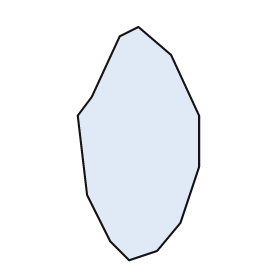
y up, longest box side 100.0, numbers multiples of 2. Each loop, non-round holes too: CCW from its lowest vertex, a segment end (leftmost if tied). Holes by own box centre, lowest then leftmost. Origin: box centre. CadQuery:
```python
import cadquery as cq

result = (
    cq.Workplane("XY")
    .moveTo(-4.0, -50.0)
    .lineTo(8.0, -46.0)
    .lineTo(18.0, -34.0)
    .lineTo(26.0, -10.0)
    .lineTo(26.0, 12.0)
    .lineTo(14.0, 38.0)
    .lineTo(0.0, 50.0)
    .lineTo(-8.0, 46.0)
    .lineTo(-20.0, 20.0)
    .lineTo(-26.0, 12.0)
    .lineTo(-22.0, -22.0)
    .lineTo(-12.0, -42.0)
    .close()
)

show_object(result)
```